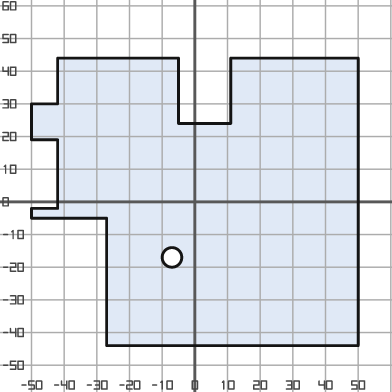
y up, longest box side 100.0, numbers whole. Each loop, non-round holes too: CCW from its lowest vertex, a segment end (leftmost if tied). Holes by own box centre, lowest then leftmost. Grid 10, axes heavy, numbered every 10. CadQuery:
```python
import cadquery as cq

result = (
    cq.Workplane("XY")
    .moveTo(-27.0, -44.0)
    .lineTo(50.0, -44.0)
    .lineTo(50.0, 44.0)
    .lineTo(11.0, 44.0)
    .lineTo(11.0, 24.0)
    .lineTo(-5.0, 24.0)
    .lineTo(-5.0, 44.0)
    .lineTo(-42.0, 44.0)
    .lineTo(-42.0, 30.0)
    .lineTo(-50.0, 30.0)
    .lineTo(-50.0, 19.0)
    .lineTo(-42.0, 19.0)
    .lineTo(-42.0, -2.0)
    .lineTo(-50.0, -2.0)
    .lineTo(-50.0, -5.0)
    .lineTo(-27.0, -5.0)
    .close()
    .moveTo(-7.0, -17.0)
    .circle(3.0)
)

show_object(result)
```